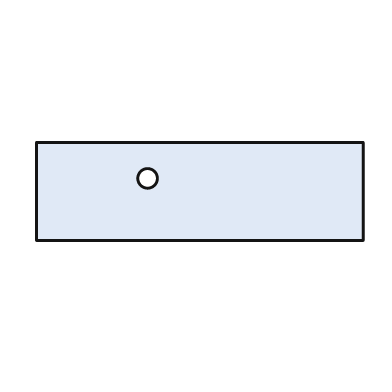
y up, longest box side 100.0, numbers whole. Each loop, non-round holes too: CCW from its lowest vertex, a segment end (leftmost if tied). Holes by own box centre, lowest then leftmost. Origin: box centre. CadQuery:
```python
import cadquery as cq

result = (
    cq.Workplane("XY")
    .moveTo(-50.0, -15.0)
    .lineTo(50.0, -15.0)
    .lineTo(50.0, 15.0)
    .lineTo(-50.0, 15.0)
    .close()
    .moveTo(-16.0, 4.0)
    .circle(3.0)
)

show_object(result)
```